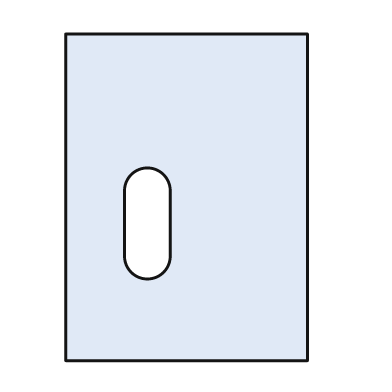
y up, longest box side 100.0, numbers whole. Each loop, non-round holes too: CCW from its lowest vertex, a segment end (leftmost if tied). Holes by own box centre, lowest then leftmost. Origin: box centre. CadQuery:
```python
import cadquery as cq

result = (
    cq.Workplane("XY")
    .moveTo(-37.0, -50.0)
    .lineTo(37.0, -50.0)
    .lineTo(37.0, 50.0)
    .lineTo(-37.0, 50.0)
    .close()
    .moveTo(-19.0, -18.0)
    .threePointArc((-12.0, -25.0), (-5.0, -18.0))
    .lineTo(-5.0, 2.0)
    .threePointArc((-12.0, 9.0), (-19.0, 2.0))
    .close()
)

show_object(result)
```